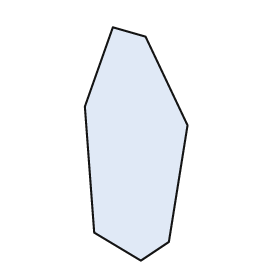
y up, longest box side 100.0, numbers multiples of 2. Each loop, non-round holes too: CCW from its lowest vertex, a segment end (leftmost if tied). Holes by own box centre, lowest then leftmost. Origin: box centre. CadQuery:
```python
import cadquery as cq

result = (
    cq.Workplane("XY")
    .moveTo(2.0, -50.0)
    .lineTo(14.0, -42.0)
    .lineTo(22.0, 8.0)
    .lineTo(4.0, 46.0)
    .lineTo(-10.0, 50.0)
    .lineTo(-22.0, 16.0)
    .lineTo(-18.0, -38.0)
    .close()
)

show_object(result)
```